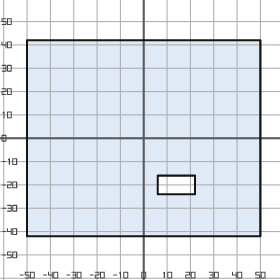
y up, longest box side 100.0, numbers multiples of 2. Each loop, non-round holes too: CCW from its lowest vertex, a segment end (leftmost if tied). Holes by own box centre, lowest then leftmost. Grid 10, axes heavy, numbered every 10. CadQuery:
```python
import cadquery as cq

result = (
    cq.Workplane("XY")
    .moveTo(-50.0, -42.0)
    .lineTo(50.0, -42.0)
    .lineTo(50.0, 42.0)
    .lineTo(-50.0, 42.0)
    .close()
    .moveTo(6.0, -24.0)
    .lineTo(22.0, -24.0)
    .lineTo(22.0, -16.0)
    .lineTo(6.0, -16.0)
    .close()
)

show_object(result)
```